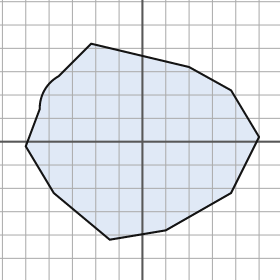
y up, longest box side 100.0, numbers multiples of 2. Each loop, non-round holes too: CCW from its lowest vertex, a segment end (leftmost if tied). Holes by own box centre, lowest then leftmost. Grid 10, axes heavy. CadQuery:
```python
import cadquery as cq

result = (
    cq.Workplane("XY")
    .moveTo(-14.0, -42.0)
    .lineTo(10.0, -38.0)
    .lineTo(38.0, -22.0)
    .lineTo(50.0, 2.0)
    .lineTo(38.0, 22.0)
    .lineTo(20.0, 32.0)
    .lineTo(-22.0, 42.0)
    .lineTo(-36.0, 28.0)
    .threePointArc((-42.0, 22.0), (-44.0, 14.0))
    .lineTo(-50.0, -2.0)
    .lineTo(-38.0, -22.0)
    .close()
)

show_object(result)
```